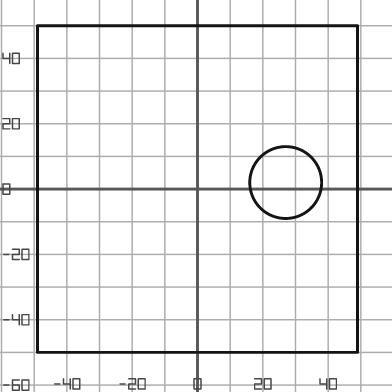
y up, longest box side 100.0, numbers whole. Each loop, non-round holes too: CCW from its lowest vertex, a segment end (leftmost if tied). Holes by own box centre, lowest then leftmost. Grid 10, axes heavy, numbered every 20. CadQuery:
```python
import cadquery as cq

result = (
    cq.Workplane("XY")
    .moveTo(-49.0, -50.0)
    .lineTo(49.0, -50.0)
    .lineTo(49.0, 50.0)
    .lineTo(-49.0, 50.0)
    .close()
    .moveTo(27.0, 2.0)
    .circle(11.0)
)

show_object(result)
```